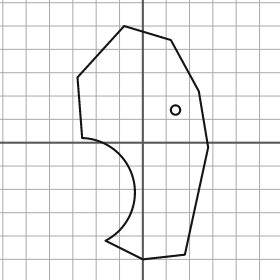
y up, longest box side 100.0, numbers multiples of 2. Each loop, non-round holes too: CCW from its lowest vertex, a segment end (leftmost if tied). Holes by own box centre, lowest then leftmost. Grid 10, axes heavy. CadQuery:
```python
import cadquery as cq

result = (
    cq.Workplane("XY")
    .moveTo(0.0, -50.0)
    .lineTo(18.0, -48.0)
    .lineTo(28.0, -2.0)
    .lineTo(24.0, 22.0)
    .lineTo(12.0, 44.0)
    .lineTo(-8.0, 50.0)
    .lineTo(-28.0, 28.0)
    .lineTo(-26.0, 2.0)
    .threePointArc((-4.0, -16.0), (-16.0, -42.0))
    .close()
    .moveTo(14.0, 14.0)
    .circle(2.0)
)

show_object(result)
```